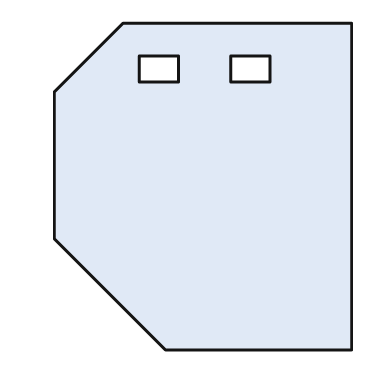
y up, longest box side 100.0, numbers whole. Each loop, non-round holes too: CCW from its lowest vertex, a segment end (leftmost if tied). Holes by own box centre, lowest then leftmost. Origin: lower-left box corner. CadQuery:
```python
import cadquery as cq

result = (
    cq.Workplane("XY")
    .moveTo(34.0, 0.0)
    .lineTo(91.0, 0.0)
    .lineTo(91.0, 100.0)
    .lineTo(21.0, 100.0)
    .lineTo(0.0, 79.0)
    .lineTo(0.0, 34.0)
    .close()
    .moveTo(26.0, 82.0)
    .lineTo(38.0, 82.0)
    .lineTo(38.0, 90.0)
    .lineTo(26.0, 90.0)
    .close()
    .moveTo(54.0, 82.0)
    .lineTo(66.0, 82.0)
    .lineTo(66.0, 90.0)
    .lineTo(54.0, 90.0)
    .close()
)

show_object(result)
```